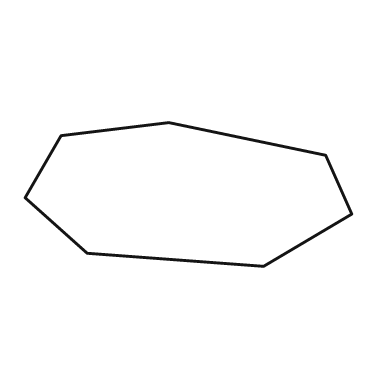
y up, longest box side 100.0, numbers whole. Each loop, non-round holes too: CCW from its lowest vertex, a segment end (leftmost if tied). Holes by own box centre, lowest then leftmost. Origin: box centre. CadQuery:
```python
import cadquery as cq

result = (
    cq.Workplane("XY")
    .moveTo(23.0, -22.0)
    .lineTo(50.0, -6.0)
    .lineTo(42.0, 12.0)
    .lineTo(-6.0, 22.0)
    .lineTo(-39.0, 18.0)
    .lineTo(-50.0, -1.0)
    .lineTo(-31.0, -18.0)
    .close()
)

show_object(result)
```